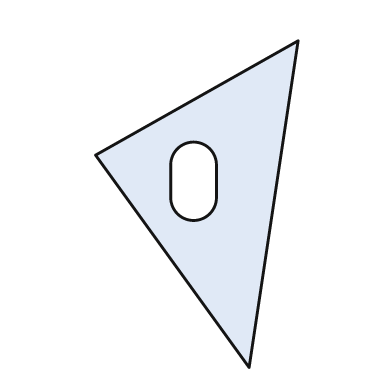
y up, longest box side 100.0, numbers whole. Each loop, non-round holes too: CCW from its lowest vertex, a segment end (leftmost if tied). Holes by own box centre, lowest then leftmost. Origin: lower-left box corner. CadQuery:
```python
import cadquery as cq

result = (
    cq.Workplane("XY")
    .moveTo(47.0, 0.0)
    .lineTo(62.0, 100.0)
    .lineTo(0.0, 65.0)
    .close()
    .moveTo(23.0, 52.0)
    .threePointArc((30.0, 45.0), (37.0, 52.0))
    .lineTo(37.0, 62.0)
    .threePointArc((30.0, 69.0), (23.0, 62.0))
    .close()
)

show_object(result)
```